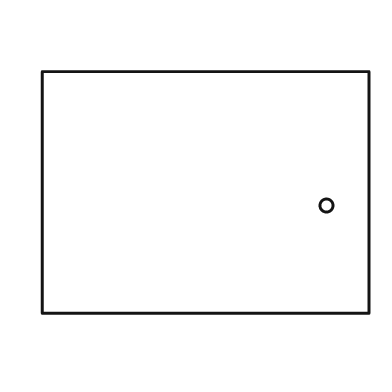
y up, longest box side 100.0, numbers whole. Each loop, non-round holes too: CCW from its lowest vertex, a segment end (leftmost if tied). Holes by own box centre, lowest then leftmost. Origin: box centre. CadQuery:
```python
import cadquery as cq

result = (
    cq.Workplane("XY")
    .moveTo(-50.0, -37.0)
    .lineTo(50.0, -37.0)
    .lineTo(50.0, 37.0)
    .lineTo(-50.0, 37.0)
    .close()
    .moveTo(37.0, -4.0)
    .circle(2.0)
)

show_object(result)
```